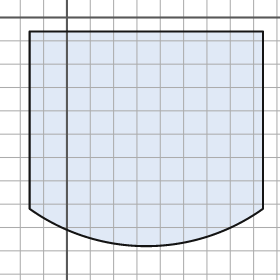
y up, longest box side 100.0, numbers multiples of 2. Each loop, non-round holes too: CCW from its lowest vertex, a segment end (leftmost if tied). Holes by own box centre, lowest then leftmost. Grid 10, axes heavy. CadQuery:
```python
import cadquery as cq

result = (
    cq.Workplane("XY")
    .moveTo(-16.0, -82.0)
    .threePointArc((34.0, -98.0), (84.0, -82.0))
    .lineTo(84.0, -6.0)
    .lineTo(-16.0, -6.0)
    .close()
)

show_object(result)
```